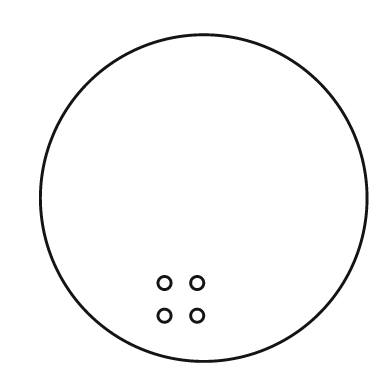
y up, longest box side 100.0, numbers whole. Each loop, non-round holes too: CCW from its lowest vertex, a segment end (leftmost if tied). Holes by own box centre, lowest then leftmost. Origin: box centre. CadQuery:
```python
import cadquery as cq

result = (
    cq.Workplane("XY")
    .moveTo(0.0, 0.0)
    .circle(50.0)
    .moveTo(-12.0, -36.0)
    .circle(2.0)
    .moveTo(-2.0, -36.0)
    .circle(2.0)
    .moveTo(-12.0, -26.0)
    .circle(2.0)
    .moveTo(-2.0, -26.0)
    .circle(2.0)
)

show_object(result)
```